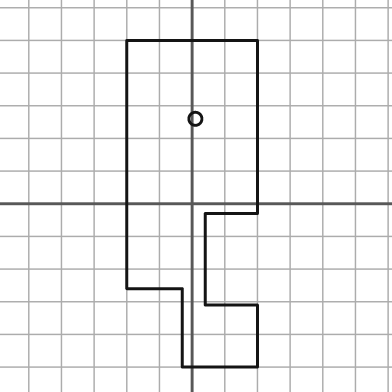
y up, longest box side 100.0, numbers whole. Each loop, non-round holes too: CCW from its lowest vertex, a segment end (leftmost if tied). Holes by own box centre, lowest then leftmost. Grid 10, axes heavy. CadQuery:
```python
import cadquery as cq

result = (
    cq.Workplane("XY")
    .moveTo(-3.0, -50.0)
    .lineTo(20.0, -50.0)
    .lineTo(20.0, -31.0)
    .lineTo(4.0, -31.0)
    .lineTo(4.0, -3.0)
    .lineTo(20.0, -3.0)
    .lineTo(20.0, 50.0)
    .lineTo(-20.0, 50.0)
    .lineTo(-20.0, -26.0)
    .lineTo(-3.0, -26.0)
    .close()
    .moveTo(1.0, 26.0)
    .circle(2.0)
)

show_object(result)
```